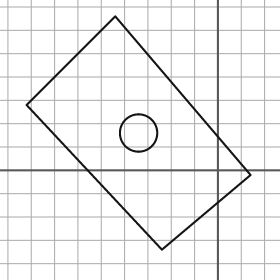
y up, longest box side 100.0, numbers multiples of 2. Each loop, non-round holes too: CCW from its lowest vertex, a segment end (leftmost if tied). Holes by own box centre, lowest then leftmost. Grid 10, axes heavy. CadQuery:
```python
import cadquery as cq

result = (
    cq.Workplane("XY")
    .moveTo(-24.0, -34.0)
    .lineTo(14.0, -2.0)
    .lineTo(-44.0, 66.0)
    .lineTo(-82.0, 28.0)
    .close()
    .moveTo(-34.0, 16.0)
    .circle(8.0)
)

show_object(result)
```